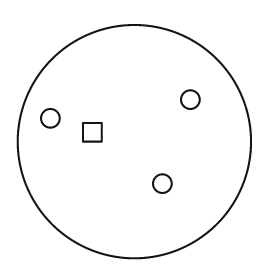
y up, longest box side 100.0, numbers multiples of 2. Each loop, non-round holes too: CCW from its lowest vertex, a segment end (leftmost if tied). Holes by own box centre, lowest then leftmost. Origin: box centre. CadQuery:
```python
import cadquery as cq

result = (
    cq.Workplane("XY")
    .moveTo(0.0, 0.0)
    .circle(50.0)
    .moveTo(12.0, -18.0)
    .circle(4.0)
    .moveTo(-22.0, 0.0)
    .lineTo(-14.0, 0.0)
    .lineTo(-14.0, 8.0)
    .lineTo(-22.0, 8.0)
    .close()
    .moveTo(-36.0, 10.0)
    .circle(4.0)
    .moveTo(24.0, 18.0)
    .circle(4.0)
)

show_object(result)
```